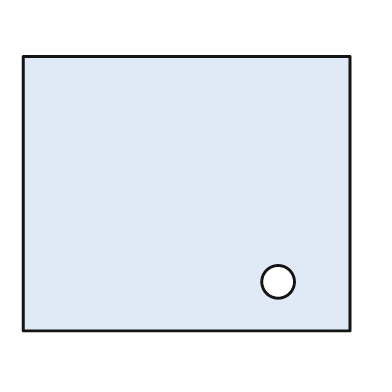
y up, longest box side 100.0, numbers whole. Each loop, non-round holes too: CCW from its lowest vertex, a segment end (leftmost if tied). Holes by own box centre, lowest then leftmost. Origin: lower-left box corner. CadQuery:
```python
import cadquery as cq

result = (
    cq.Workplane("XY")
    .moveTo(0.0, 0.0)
    .lineTo(100.0, 0.0)
    .lineTo(100.0, 84.0)
    .lineTo(0.0, 84.0)
    .close()
    .moveTo(78.0, 15.0)
    .circle(5.0)
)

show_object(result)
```